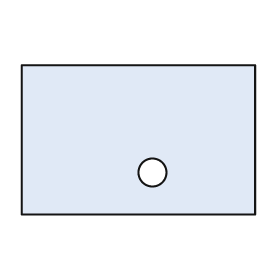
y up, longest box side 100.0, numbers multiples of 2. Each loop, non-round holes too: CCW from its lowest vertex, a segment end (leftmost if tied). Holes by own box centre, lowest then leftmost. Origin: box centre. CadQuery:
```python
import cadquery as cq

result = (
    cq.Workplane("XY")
    .moveTo(-50.0, -32.0)
    .lineTo(50.0, -32.0)
    .lineTo(50.0, 32.0)
    .lineTo(-50.0, 32.0)
    .close()
    .moveTo(6.0, -14.0)
    .circle(6.0)
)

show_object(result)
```